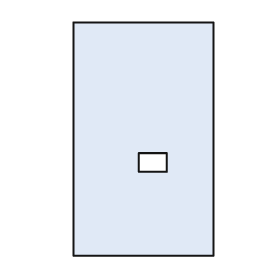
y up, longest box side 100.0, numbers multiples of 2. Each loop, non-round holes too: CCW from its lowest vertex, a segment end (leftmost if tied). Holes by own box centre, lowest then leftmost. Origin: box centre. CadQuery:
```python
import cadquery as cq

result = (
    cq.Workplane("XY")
    .moveTo(-30.0, -50.0)
    .lineTo(30.0, -50.0)
    .lineTo(30.0, 50.0)
    .lineTo(-30.0, 50.0)
    .close()
    .moveTo(-2.0, -14.0)
    .lineTo(10.0, -14.0)
    .lineTo(10.0, -6.0)
    .lineTo(-2.0, -6.0)
    .close()
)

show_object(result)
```